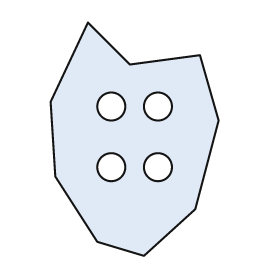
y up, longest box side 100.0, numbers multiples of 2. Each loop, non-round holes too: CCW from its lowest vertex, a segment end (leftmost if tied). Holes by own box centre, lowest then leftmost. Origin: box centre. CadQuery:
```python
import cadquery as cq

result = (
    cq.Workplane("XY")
    .moveTo(4.0, -50.0)
    .lineTo(26.0, -30.0)
    .lineTo(36.0, 8.0)
    .lineTo(28.0, 36.0)
    .lineTo(-2.0, 32.0)
    .lineTo(-20.0, 50.0)
    .lineTo(-36.0, 16.0)
    .lineTo(-34.0, -16.0)
    .lineTo(-16.0, -44.0)
    .close()
    .moveTo(-10.0, -12.0)
    .circle(6.0)
    .moveTo(10.0, -12.0)
    .circle(6.0)
    .moveTo(-10.0, 14.0)
    .circle(6.0)
    .moveTo(10.0, 14.0)
    .circle(6.0)
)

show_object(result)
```